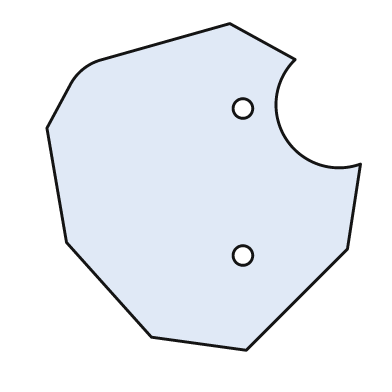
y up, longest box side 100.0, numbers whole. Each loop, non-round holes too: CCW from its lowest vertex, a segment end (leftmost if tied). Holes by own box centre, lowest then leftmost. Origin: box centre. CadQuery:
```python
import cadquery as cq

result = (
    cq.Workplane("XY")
    .moveTo(13.0, -50.0)
    .lineTo(44.0, -19.0)
    .lineTo(48.0, 7.0)
    .threePointArc((25.0, 15.0), (28.0, 39.0))
    .lineTo(8.0, 50.0)
    .lineTo(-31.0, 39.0)
    .threePointArc((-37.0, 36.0), (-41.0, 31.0))
    .lineTo(-48.0, 18.0)
    .lineTo(-42.0, -17.0)
    .lineTo(-16.0, -46.0)
    .close()
    .moveTo(12.0, -21.0)
    .circle(3.0)
    .moveTo(12.0, 24.0)
    .circle(3.0)
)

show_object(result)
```